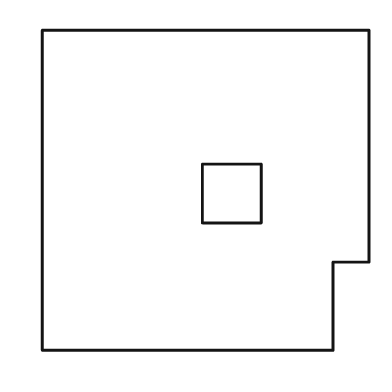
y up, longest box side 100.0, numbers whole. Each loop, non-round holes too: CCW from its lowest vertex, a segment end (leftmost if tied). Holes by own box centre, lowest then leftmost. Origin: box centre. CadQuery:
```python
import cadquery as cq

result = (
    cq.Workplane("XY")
    .moveTo(-50.0, -49.0)
    .lineTo(39.0, -49.0)
    .lineTo(39.0, -22.0)
    .lineTo(50.0, -22.0)
    .lineTo(50.0, 49.0)
    .lineTo(-50.0, 49.0)
    .close()
    .moveTo(-1.0, -10.0)
    .lineTo(17.0, -10.0)
    .lineTo(17.0, 8.0)
    .lineTo(-1.0, 8.0)
    .close()
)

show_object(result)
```